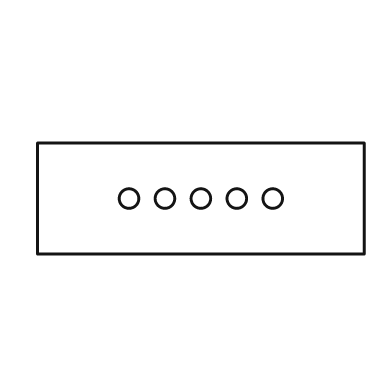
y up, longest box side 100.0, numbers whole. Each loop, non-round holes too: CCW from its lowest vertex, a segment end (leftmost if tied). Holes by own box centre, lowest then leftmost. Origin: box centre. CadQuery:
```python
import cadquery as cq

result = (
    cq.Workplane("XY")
    .moveTo(-50.0, -17.0)
    .lineTo(50.0, -17.0)
    .lineTo(50.0, 17.0)
    .lineTo(-50.0, 17.0)
    .close()
    .moveTo(-22.0, 0.0)
    .circle(3.0)
    .moveTo(-11.0, 0.0)
    .circle(3.0)
    .moveTo(0.0, 0.0)
    .circle(3.0)
    .moveTo(11.0, 0.0)
    .circle(3.0)
    .moveTo(22.0, 0.0)
    .circle(3.0)
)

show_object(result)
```